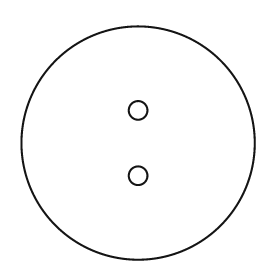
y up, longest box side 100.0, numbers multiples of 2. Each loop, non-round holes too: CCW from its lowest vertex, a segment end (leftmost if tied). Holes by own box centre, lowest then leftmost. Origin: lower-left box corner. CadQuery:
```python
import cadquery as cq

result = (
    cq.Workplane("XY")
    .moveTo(50.0, 50.0)
    .circle(50.0)
    .moveTo(50.0, 36.0)
    .circle(4.0)
    .moveTo(50.0, 64.0)
    .circle(4.0)
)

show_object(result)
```